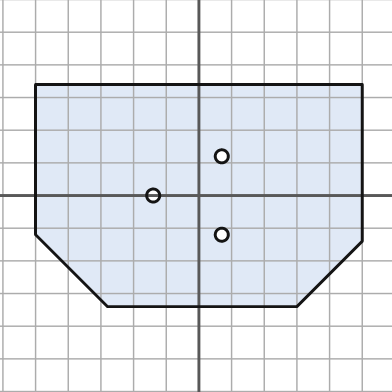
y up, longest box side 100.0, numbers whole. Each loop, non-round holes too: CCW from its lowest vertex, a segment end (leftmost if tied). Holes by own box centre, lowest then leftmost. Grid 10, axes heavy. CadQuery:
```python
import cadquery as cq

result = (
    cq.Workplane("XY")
    .moveTo(-28.0, -34.0)
    .lineTo(30.0, -34.0)
    .lineTo(50.0, -14.0)
    .lineTo(50.0, 34.0)
    .lineTo(-50.0, 34.0)
    .lineTo(-50.0, -12.0)
    .close()
    .moveTo(7.0, -12.0)
    .circle(2.0)
    .moveTo(-14.0, 0.0)
    .circle(2.0)
    .moveTo(7.0, 12.0)
    .circle(2.0)
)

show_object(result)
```